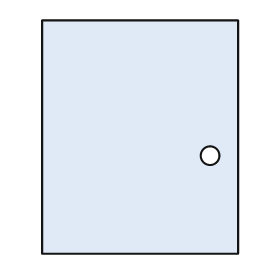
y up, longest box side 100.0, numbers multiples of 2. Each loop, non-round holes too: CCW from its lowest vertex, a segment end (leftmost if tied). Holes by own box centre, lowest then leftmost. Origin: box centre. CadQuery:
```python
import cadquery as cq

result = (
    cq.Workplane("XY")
    .moveTo(-42.0, -50.0)
    .lineTo(42.0, -50.0)
    .lineTo(42.0, 50.0)
    .lineTo(-42.0, 50.0)
    .close()
    .moveTo(30.0, -8.0)
    .circle(4.0)
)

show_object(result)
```